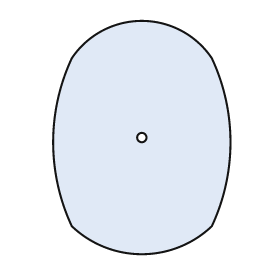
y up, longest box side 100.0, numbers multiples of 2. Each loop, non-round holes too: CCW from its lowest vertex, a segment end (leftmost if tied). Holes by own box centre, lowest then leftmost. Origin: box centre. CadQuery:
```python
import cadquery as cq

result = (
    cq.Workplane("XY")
    .moveTo(-30.0, -38.0)
    .threePointArc((0.0, -50.0), (30.0, -38.0))
    .threePointArc((38.0, -2.0), (30.0, 34.0))
    .threePointArc((0.0, 50.0), (-30.0, 34.0))
    .threePointArc((-38.0, -2.0), (-30.0, -38.0))
    .close()
    .moveTo(0.0, 0.0)
    .circle(2.0)
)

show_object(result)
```